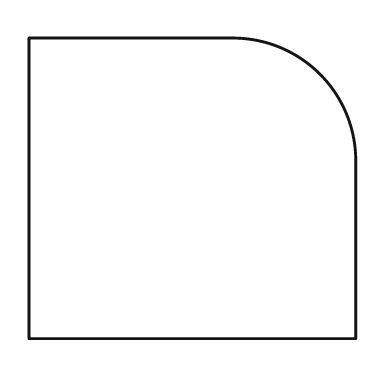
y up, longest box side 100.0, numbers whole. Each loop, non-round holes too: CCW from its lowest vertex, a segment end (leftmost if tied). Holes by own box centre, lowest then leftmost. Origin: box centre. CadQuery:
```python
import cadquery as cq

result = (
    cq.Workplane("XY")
    .moveTo(-50.0, -46.0)
    .lineTo(50.0, -46.0)
    .lineTo(50.0, 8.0)
    .threePointArc((39.0, 35.0), (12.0, 46.0))
    .lineTo(-50.0, 46.0)
    .close()
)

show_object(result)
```